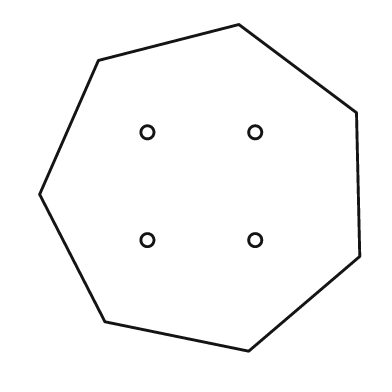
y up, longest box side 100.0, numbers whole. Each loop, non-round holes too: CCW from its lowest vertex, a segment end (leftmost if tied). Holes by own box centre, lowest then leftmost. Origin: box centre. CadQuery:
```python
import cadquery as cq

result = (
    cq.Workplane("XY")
    .moveTo(15.0, -50.0)
    .lineTo(49.0, -21.0)
    .lineTo(48.0, 23.0)
    .lineTo(12.0, 50.0)
    .lineTo(-31.0, 39.0)
    .lineTo(-49.0, -2.0)
    .lineTo(-29.0, -41.0)
    .close()
    .moveTo(-16.0, -16.0)
    .circle(2.0)
    .moveTo(17.0, -16.0)
    .circle(2.0)
    .moveTo(-16.0, 17.0)
    .circle(2.0)
    .moveTo(17.0, 17.0)
    .circle(2.0)
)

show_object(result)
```